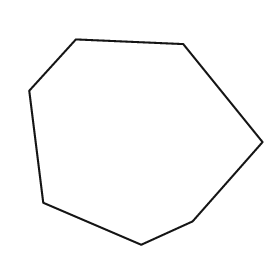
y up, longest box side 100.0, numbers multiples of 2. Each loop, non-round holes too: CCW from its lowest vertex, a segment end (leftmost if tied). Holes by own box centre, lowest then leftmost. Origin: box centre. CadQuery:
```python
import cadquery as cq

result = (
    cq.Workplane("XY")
    .moveTo(-2.0, -44.0)
    .lineTo(20.0, -34.0)
    .lineTo(50.0, 0.0)
    .lineTo(16.0, 42.0)
    .lineTo(-30.0, 44.0)
    .lineTo(-50.0, 22.0)
    .lineTo(-44.0, -26.0)
    .close()
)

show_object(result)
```